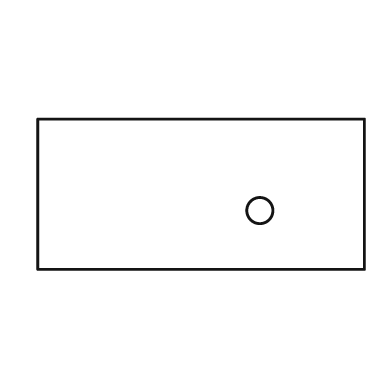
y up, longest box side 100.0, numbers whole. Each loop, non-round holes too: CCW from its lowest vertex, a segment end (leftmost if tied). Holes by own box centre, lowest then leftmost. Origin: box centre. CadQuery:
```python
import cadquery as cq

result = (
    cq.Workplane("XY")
    .moveTo(-50.0, -23.0)
    .lineTo(50.0, -23.0)
    .lineTo(50.0, 23.0)
    .lineTo(-50.0, 23.0)
    .close()
    .moveTo(18.0, -5.0)
    .circle(4.0)
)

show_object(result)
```